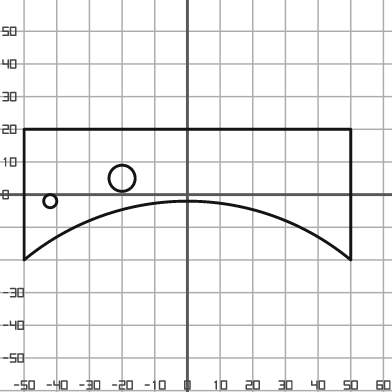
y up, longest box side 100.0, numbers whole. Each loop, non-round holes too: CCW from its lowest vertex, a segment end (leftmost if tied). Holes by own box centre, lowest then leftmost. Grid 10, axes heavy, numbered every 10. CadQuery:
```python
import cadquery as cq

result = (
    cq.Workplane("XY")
    .moveTo(-50.0, -20.0)
    .threePointArc((0.0, -2.0), (50.0, -20.0))
    .lineTo(50.0, 20.0)
    .lineTo(-50.0, 20.0)
    .close()
    .moveTo(-42.0, -2.0)
    .circle(2.0)
    .moveTo(-20.0, 5.0)
    .circle(4.0)
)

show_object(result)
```